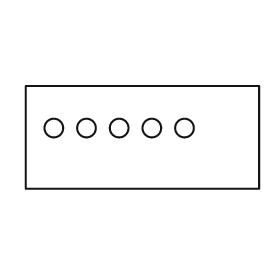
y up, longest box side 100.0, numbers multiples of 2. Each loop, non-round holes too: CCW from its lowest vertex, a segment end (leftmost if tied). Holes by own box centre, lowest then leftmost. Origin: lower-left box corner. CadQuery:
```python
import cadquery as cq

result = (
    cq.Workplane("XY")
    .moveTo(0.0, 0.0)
    .lineTo(100.0, 0.0)
    .lineTo(100.0, 44.0)
    .lineTo(0.0, 44.0)
    .close()
    .moveTo(12.0, 26.0)
    .circle(4.0)
    .moveTo(26.0, 26.0)
    .circle(4.0)
    .moveTo(40.0, 26.0)
    .circle(4.0)
    .moveTo(54.0, 26.0)
    .circle(4.0)
    .moveTo(68.0, 26.0)
    .circle(4.0)
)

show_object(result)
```